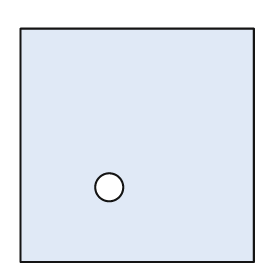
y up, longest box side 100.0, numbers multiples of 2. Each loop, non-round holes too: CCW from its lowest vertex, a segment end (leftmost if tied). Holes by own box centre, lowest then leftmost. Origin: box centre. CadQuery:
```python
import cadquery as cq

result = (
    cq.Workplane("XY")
    .moveTo(-50.0, -50.0)
    .lineTo(50.0, -50.0)
    .lineTo(50.0, 50.0)
    .lineTo(-50.0, 50.0)
    .close()
    .moveTo(-12.0, -18.0)
    .circle(6.0)
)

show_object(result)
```